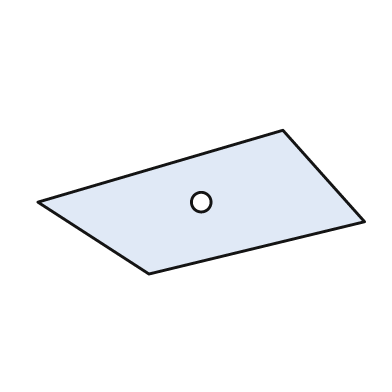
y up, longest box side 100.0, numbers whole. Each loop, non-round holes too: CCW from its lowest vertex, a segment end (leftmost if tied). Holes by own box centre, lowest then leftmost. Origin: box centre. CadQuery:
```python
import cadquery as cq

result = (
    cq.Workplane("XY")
    .moveTo(-16.0, -22.0)
    .lineTo(50.0, -6.0)
    .lineTo(25.0, 22.0)
    .lineTo(-50.0, 0.0)
    .close()
    .moveTo(0.0, 0.0)
    .circle(3.0)
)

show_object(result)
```